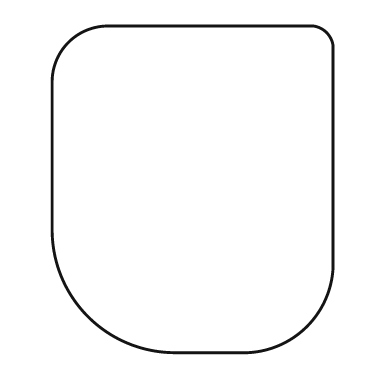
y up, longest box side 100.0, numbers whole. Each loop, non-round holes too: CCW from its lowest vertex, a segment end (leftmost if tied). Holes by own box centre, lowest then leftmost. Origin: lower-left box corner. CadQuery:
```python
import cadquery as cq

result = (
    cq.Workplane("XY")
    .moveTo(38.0, 0.0)
    .lineTo(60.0, 0.0)
    .threePointArc((78.0, 8.0), (86.0, 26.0))
    .lineTo(86.0, 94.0)
    .threePointArc((84.0, 98.0), (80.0, 100.0))
    .lineTo(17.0, 100.0)
    .threePointArc((5.0, 95.0), (0.0, 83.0))
    .lineTo(0.0, 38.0)
    .threePointArc((11.0, 11.0), (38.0, 0.0))
    .close()
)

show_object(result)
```